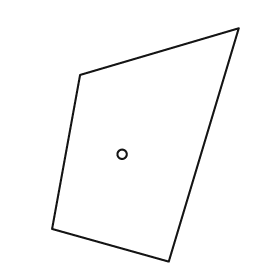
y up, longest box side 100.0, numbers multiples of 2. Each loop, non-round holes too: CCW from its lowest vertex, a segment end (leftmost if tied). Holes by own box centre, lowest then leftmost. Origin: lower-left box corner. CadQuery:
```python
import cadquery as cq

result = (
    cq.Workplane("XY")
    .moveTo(50.0, 0.0)
    .lineTo(80.0, 100.0)
    .lineTo(12.0, 80.0)
    .lineTo(0.0, 14.0)
    .close()
    .moveTo(30.0, 46.0)
    .circle(2.0)
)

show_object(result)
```